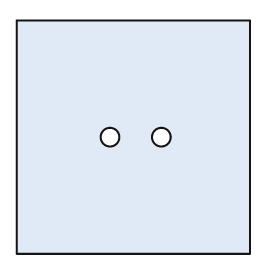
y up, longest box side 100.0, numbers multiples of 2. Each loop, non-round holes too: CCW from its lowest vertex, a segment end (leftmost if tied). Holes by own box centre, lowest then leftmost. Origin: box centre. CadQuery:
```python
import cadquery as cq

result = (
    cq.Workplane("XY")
    .moveTo(-50.0, -50.0)
    .lineTo(50.0, -50.0)
    .lineTo(50.0, 50.0)
    .lineTo(-50.0, 50.0)
    .close()
    .moveTo(-10.0, 0.0)
    .circle(4.0)
    .moveTo(12.0, 0.0)
    .circle(4.0)
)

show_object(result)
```